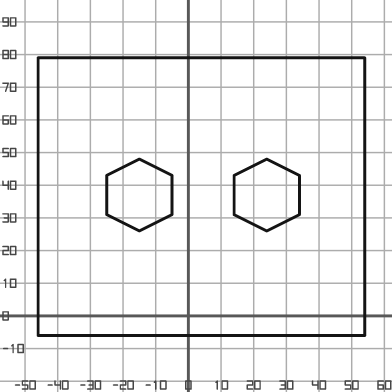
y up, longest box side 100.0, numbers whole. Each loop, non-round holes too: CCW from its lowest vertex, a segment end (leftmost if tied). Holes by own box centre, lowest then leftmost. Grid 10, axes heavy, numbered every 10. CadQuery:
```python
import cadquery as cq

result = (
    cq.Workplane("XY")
    .moveTo(-46.0, -6.0)
    .lineTo(54.0, -6.0)
    .lineTo(54.0, 79.0)
    .lineTo(-46.0, 79.0)
    .close()
    .moveTo(-15.0, 26.0)
    .lineTo(-5.0, 31.0)
    .lineTo(-5.0, 43.0)
    .lineTo(-15.0, 48.0)
    .lineTo(-25.0, 43.0)
    .lineTo(-25.0, 31.0)
    .close()
    .moveTo(24.0, 26.0)
    .lineTo(34.0, 31.0)
    .lineTo(34.0, 43.0)
    .lineTo(24.0, 48.0)
    .lineTo(14.0, 43.0)
    .lineTo(14.0, 31.0)
    .close()
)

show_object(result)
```